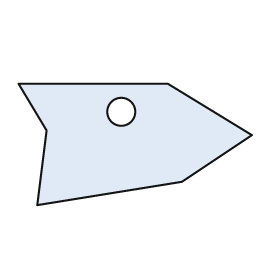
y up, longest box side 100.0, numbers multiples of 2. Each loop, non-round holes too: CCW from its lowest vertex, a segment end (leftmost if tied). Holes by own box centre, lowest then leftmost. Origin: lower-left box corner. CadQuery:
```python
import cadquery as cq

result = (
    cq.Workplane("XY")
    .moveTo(8.0, 0.0)
    .lineTo(70.0, 10.0)
    .lineTo(100.0, 30.0)
    .lineTo(64.0, 52.0)
    .lineTo(0.0, 52.0)
    .lineTo(12.0, 32.0)
    .close()
    .moveTo(44.0, 40.0)
    .circle(6.0)
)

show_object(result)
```